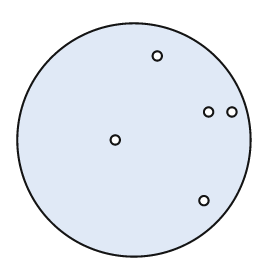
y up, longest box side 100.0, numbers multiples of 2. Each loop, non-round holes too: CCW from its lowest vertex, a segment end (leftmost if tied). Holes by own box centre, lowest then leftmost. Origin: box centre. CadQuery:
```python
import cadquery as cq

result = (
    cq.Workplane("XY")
    .moveTo(0.0, 0.0)
    .circle(50.0)
    .moveTo(30.0, -26.0)
    .circle(2.0)
    .moveTo(-8.0, 0.0)
    .circle(2.0)
    .moveTo(32.0, 12.0)
    .circle(2.0)
    .moveTo(42.0, 12.0)
    .circle(2.0)
    .moveTo(10.0, 36.0)
    .circle(2.0)
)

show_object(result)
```